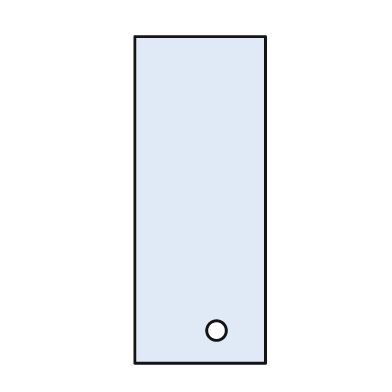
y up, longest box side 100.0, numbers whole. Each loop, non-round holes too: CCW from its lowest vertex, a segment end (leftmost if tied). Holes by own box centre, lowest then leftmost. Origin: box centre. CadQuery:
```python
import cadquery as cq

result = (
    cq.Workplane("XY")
    .moveTo(-20.0, -50.0)
    .lineTo(20.0, -50.0)
    .lineTo(20.0, 50.0)
    .lineTo(-20.0, 50.0)
    .close()
    .moveTo(5.0, -40.0)
    .circle(3.0)
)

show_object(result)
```